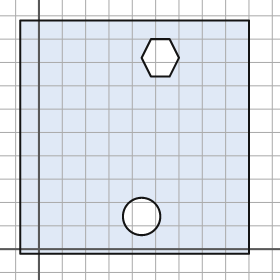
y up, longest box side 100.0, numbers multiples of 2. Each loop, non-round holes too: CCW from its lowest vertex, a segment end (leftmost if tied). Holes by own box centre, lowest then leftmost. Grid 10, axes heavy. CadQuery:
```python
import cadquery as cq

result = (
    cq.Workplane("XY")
    .moveTo(-8.0, -2.0)
    .lineTo(90.0, -2.0)
    .lineTo(90.0, 98.0)
    .lineTo(-8.0, 98.0)
    .close()
    .moveTo(44.0, 14.0)
    .circle(8.0)
    .moveTo(48.0, 74.0)
    .lineTo(56.0, 74.0)
    .lineTo(60.0, 82.0)
    .lineTo(56.0, 90.0)
    .lineTo(48.0, 90.0)
    .lineTo(44.0, 82.0)
    .close()
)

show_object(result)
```